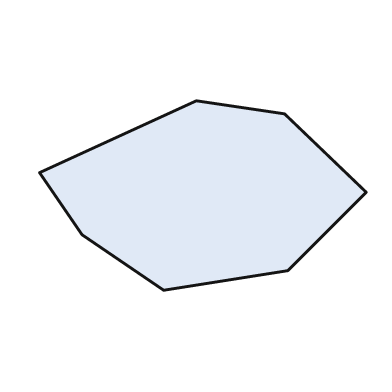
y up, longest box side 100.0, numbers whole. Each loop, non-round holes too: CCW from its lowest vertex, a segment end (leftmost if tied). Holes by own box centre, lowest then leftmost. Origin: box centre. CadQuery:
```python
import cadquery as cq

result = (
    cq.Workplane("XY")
    .moveTo(-12.0, -29.0)
    .lineTo(26.0, -23.0)
    .lineTo(50.0, 1.0)
    .lineTo(25.0, 25.0)
    .lineTo(-2.0, 29.0)
    .lineTo(-50.0, 7.0)
    .lineTo(-37.0, -12.0)
    .close()
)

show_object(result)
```